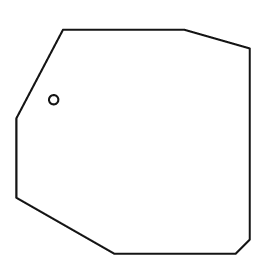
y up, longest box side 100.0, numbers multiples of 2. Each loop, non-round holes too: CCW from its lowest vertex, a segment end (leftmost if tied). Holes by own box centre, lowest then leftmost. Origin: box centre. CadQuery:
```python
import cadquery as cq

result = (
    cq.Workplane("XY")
    .moveTo(-8.0, -48.0)
    .lineTo(44.0, -48.0)
    .lineTo(50.0, -42.0)
    .lineTo(50.0, 40.0)
    .lineTo(22.0, 48.0)
    .lineTo(-30.0, 48.0)
    .lineTo(-50.0, 10.0)
    .lineTo(-50.0, -24.0)
    .close()
    .moveTo(-34.0, 18.0)
    .circle(2.0)
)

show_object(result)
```